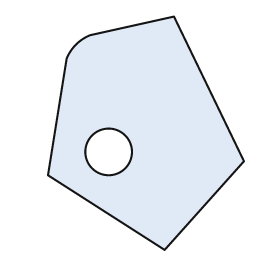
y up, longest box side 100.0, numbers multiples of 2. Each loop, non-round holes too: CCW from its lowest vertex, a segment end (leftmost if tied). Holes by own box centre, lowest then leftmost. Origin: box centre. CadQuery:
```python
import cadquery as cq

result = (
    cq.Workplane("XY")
    .moveTo(8.0, -50.0)
    .lineTo(42.0, -12.0)
    .lineTo(12.0, 50.0)
    .lineTo(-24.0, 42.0)
    .threePointArc((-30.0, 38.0), (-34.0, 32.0))
    .lineTo(-42.0, -18.0)
    .close()
    .moveTo(-16.0, -8.0)
    .circle(10.0)
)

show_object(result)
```